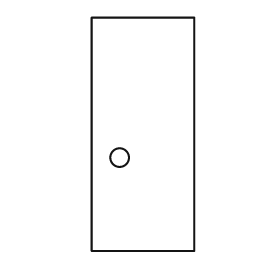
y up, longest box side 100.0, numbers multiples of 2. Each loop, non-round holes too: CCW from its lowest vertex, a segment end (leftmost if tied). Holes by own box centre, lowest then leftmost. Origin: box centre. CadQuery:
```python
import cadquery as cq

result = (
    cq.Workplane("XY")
    .moveTo(-22.0, -50.0)
    .lineTo(22.0, -50.0)
    .lineTo(22.0, 50.0)
    .lineTo(-22.0, 50.0)
    .close()
    .moveTo(-10.0, -10.0)
    .circle(4.0)
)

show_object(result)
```